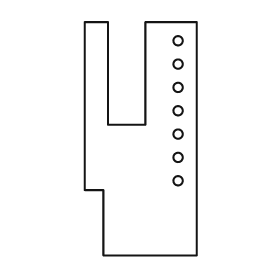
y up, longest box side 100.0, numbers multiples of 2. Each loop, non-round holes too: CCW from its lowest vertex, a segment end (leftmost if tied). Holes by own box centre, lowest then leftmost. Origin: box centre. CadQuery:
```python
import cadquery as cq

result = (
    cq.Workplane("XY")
    .moveTo(-16.0, -50.0)
    .lineTo(24.0, -50.0)
    .lineTo(24.0, 50.0)
    .lineTo(2.0, 50.0)
    .lineTo(2.0, 6.0)
    .lineTo(-14.0, 6.0)
    .lineTo(-14.0, 50.0)
    .lineTo(-24.0, 50.0)
    .lineTo(-24.0, -22.0)
    .lineTo(-16.0, -22.0)
    .close()
    .moveTo(16.0, -18.0)
    .circle(2.0)
    .moveTo(16.0, -8.0)
    .circle(2.0)
    .moveTo(16.0, 2.0)
    .circle(2.0)
    .moveTo(16.0, 12.0)
    .circle(2.0)
    .moveTo(16.0, 22.0)
    .circle(2.0)
    .moveTo(16.0, 32.0)
    .circle(2.0)
    .moveTo(16.0, 42.0)
    .circle(2.0)
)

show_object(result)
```